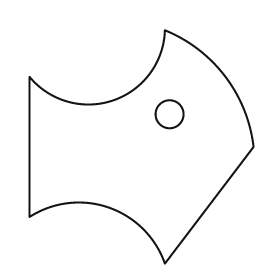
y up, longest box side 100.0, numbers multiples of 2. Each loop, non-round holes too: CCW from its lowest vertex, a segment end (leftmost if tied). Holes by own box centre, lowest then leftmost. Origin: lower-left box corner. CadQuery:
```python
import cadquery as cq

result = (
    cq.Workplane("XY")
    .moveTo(58.0, 0.0)
    .lineTo(96.0, 50.0)
    .threePointArc((84.0, 80.0), (58.0, 100.0))
    .threePointArc((36.0, 70.0), (0.0, 80.0))
    .lineTo(0.0, 20.0)
    .threePointArc((34.0, 24.0), (58.0, 0.0))
    .close()
    .moveTo(60.0, 64.0)
    .circle(6.0)
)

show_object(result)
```